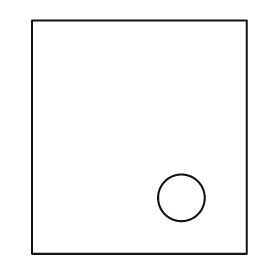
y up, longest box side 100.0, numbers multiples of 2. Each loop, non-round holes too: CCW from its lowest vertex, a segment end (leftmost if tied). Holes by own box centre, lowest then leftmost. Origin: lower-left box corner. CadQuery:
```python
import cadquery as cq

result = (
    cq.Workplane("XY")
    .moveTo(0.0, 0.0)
    .lineTo(92.0, 0.0)
    .lineTo(92.0, 100.0)
    .lineTo(0.0, 100.0)
    .close()
    .moveTo(64.0, 24.0)
    .circle(10.0)
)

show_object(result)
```